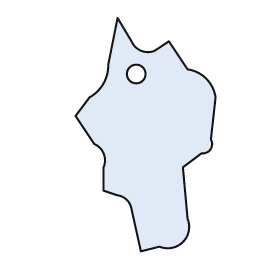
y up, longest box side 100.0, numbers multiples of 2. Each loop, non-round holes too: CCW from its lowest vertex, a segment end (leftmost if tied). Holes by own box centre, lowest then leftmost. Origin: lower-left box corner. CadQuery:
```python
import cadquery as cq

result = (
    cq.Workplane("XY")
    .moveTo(28.0, 0.0)
    .lineTo(36.0, 2.0)
    .threePointArc((46.0, 4.0), (48.0, 14.0))
    .lineTo(46.0, 36.0)
    .lineTo(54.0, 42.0)
    .threePointArc((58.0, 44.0), (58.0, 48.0))
    .lineTo(60.0, 66.0)
    .threePointArc((56.0, 74.0), (48.0, 78.0))
    .lineTo(40.0, 90.0)
    .lineTo(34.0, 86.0)
    .threePointArc((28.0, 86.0), (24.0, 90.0))
    .lineTo(18.0, 100.0)
    .lineTo(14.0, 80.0)
    .threePointArc((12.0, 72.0), (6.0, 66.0))
    .lineTo(0.0, 58.0)
    .lineTo(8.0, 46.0)
    .threePointArc((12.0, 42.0), (12.0, 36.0))
    .lineTo(12.0, 26.0)
    .lineTo(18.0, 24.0)
    .threePointArc((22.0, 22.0), (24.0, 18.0))
    .close()
    .moveTo(26.0, 76.0)
    .circle(4.0)
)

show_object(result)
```